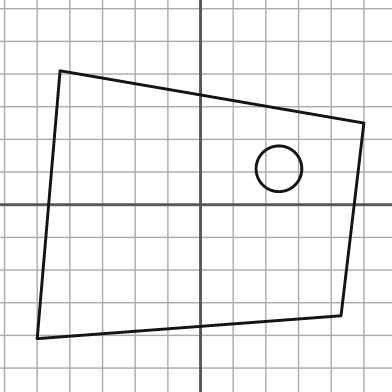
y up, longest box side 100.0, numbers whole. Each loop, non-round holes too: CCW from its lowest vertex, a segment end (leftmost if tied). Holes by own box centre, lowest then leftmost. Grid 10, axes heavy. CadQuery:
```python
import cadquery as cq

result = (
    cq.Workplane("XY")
    .moveTo(-50.0, -41.0)
    .lineTo(43.0, -34.0)
    .lineTo(50.0, 25.0)
    .lineTo(-43.0, 41.0)
    .close()
    .moveTo(24.0, 11.0)
    .circle(7.0)
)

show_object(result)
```